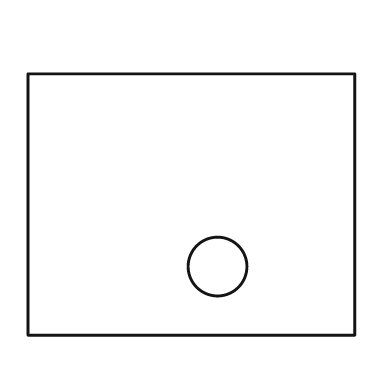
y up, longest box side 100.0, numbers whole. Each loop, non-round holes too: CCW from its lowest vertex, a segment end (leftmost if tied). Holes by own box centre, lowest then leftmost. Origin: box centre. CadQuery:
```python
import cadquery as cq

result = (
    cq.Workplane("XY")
    .moveTo(-50.0, -40.0)
    .lineTo(50.0, -40.0)
    .lineTo(50.0, 40.0)
    .lineTo(-50.0, 40.0)
    .close()
    .moveTo(8.0, -19.0)
    .circle(9.0)
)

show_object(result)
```